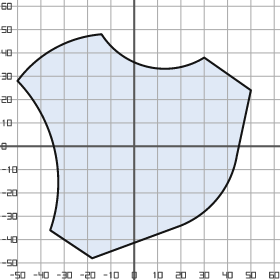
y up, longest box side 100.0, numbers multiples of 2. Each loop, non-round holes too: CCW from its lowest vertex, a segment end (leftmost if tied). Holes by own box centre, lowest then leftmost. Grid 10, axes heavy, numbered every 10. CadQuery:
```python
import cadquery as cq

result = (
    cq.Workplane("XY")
    .moveTo(-18.0, -48.0)
    .lineTo(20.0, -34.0)
    .threePointArc((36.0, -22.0), (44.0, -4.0))
    .lineTo(50.0, 24.0)
    .lineTo(30.0, 38.0)
    .threePointArc((6.0, 34.0), (-14.0, 48.0))
    .threePointArc((-34.0, 42.0), (-50.0, 28.0))
    .threePointArc((-34.0, -2.0), (-36.0, -36.0))
    .close()
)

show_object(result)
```